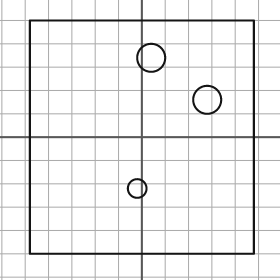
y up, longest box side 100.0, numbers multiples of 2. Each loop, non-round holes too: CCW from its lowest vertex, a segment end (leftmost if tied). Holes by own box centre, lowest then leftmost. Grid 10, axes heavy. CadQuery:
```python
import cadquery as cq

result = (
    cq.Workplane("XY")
    .moveTo(-48.0, -50.0)
    .lineTo(48.0, -50.0)
    .lineTo(48.0, 50.0)
    .lineTo(-48.0, 50.0)
    .close()
    .moveTo(-2.0, -22.0)
    .circle(4.0)
    .moveTo(28.0, 16.0)
    .circle(6.0)
    .moveTo(4.0, 34.0)
    .circle(6.0)
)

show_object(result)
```